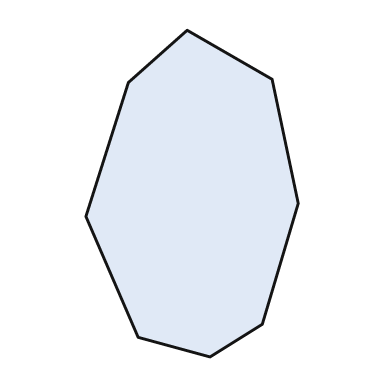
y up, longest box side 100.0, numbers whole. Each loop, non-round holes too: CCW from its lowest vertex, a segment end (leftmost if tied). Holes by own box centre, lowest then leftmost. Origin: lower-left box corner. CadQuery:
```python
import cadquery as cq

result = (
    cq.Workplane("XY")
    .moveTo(38.0, 0.0)
    .lineTo(54.0, 10.0)
    .lineTo(65.0, 47.0)
    .lineTo(57.0, 85.0)
    .lineTo(31.0, 100.0)
    .lineTo(13.0, 84.0)
    .lineTo(0.0, 43.0)
    .lineTo(16.0, 6.0)
    .close()
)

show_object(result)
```